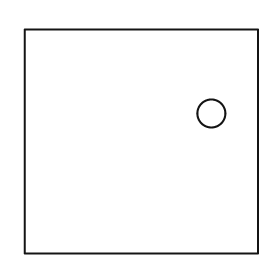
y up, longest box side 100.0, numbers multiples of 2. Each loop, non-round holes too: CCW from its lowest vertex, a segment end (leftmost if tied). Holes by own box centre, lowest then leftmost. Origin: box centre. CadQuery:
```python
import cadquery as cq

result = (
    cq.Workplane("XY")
    .moveTo(-50.0, -48.0)
    .lineTo(50.0, -48.0)
    .lineTo(50.0, 48.0)
    .lineTo(-50.0, 48.0)
    .close()
    .moveTo(30.0, 12.0)
    .circle(6.0)
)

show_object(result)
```